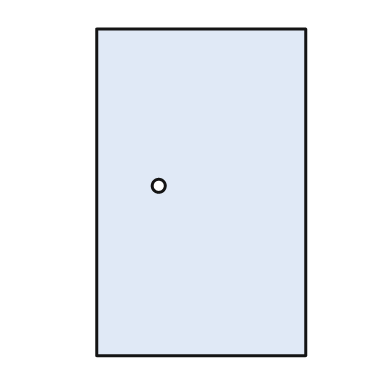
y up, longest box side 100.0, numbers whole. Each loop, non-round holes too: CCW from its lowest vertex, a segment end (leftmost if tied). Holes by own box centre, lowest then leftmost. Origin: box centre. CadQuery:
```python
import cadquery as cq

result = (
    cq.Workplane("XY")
    .moveTo(-32.0, -50.0)
    .lineTo(32.0, -50.0)
    .lineTo(32.0, 50.0)
    .lineTo(-32.0, 50.0)
    .close()
    .moveTo(-13.0, 2.0)
    .circle(2.0)
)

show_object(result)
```